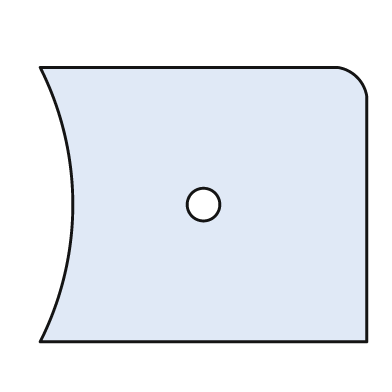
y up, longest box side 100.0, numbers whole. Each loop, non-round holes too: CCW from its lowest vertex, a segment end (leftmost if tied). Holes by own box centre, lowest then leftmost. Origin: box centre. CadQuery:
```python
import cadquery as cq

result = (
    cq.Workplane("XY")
    .moveTo(-50.0, -42.0)
    .lineTo(50.0, -42.0)
    .lineTo(50.0, 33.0)
    .threePointArc((47.0, 39.0), (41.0, 42.0))
    .lineTo(-50.0, 42.0)
    .threePointArc((-40.0, 0.0), (-50.0, -42.0))
    .close()
    .moveTo(0.0, 0.0)
    .circle(5.0)
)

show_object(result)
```